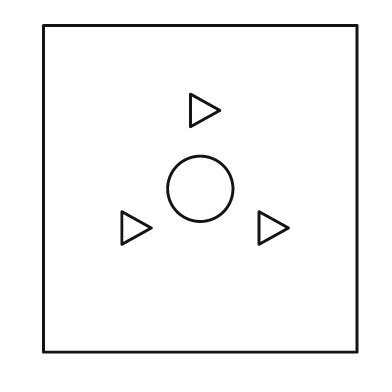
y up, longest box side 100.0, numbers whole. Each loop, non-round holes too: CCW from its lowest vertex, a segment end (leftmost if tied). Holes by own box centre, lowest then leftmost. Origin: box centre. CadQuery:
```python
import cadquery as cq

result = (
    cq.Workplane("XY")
    .moveTo(-48.0, -50.0)
    .lineTo(48.0, -50.0)
    .lineTo(48.0, 50.0)
    .lineTo(-48.0, 50.0)
    .close()
    .moveTo(-24.0, -17.0)
    .lineTo(-15.0, -12.0)
    .lineTo(-24.0, -7.0)
    .close()
    .moveTo(18.0, -17.0)
    .lineTo(27.0, -12.0)
    .lineTo(18.0, -7.0)
    .close()
    .moveTo(0.0, 0.0)
    .circle(10.0)
    .moveTo(-3.0, 19.0)
    .lineTo(6.0, 24.0)
    .lineTo(-3.0, 29.0)
    .close()
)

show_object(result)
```